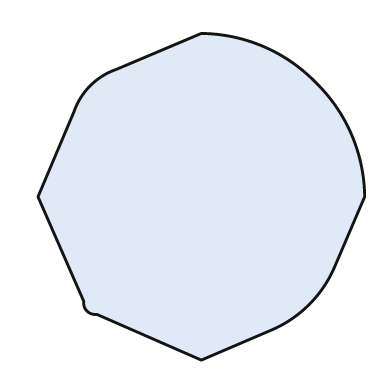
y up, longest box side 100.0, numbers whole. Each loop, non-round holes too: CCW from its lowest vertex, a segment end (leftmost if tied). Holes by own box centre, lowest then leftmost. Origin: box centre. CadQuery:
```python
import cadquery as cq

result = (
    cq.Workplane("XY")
    .moveTo(0.0, -50.0)
    .lineTo(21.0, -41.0)
    .threePointArc((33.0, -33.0), (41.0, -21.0))
    .lineTo(50.0, 0.0)
    .threePointArc((46.0, 19.0), (35.0, 35.0))
    .threePointArc((19.0, 46.0), (0.0, 50.0))
    .lineTo(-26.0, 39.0)
    .threePointArc((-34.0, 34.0), (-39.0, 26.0))
    .lineTo(-50.0, 0.0)
    .lineTo(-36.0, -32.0)
    .threePointArc((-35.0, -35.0), (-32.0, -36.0))
    .close()
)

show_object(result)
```